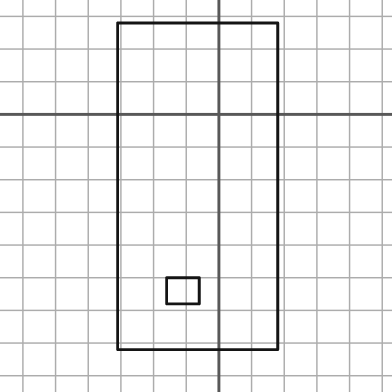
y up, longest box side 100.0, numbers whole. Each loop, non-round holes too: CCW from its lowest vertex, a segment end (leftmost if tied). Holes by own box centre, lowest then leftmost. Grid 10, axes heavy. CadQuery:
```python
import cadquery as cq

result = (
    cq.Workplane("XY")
    .moveTo(-31.0, -72.0)
    .lineTo(18.0, -72.0)
    .lineTo(18.0, 28.0)
    .lineTo(-31.0, 28.0)
    .close()
    .moveTo(-16.0, -58.0)
    .lineTo(-6.0, -58.0)
    .lineTo(-6.0, -50.0)
    .lineTo(-16.0, -50.0)
    .close()
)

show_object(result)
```